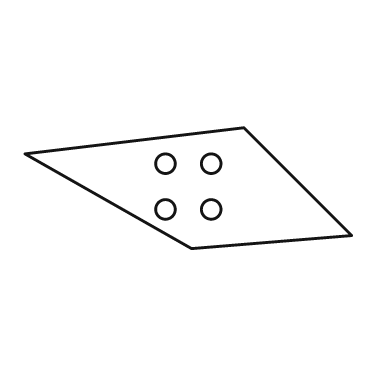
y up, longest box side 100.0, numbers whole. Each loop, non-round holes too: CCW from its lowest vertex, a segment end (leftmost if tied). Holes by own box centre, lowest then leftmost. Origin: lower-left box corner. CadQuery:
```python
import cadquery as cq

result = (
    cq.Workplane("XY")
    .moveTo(51.0, 0.0)
    .lineTo(100.0, 4.0)
    .lineTo(67.0, 37.0)
    .lineTo(0.0, 29.0)
    .close()
    .moveTo(43.0, 12.0)
    .circle(3.0)
    .moveTo(57.0, 12.0)
    .circle(3.0)
    .moveTo(43.0, 26.0)
    .circle(3.0)
    .moveTo(57.0, 26.0)
    .circle(3.0)
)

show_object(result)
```